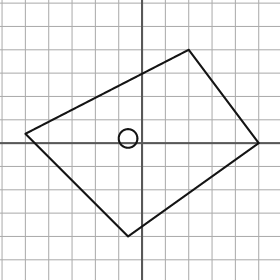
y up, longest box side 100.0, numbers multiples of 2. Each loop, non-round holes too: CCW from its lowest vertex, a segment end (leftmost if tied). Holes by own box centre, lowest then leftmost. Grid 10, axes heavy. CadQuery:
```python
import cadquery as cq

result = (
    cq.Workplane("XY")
    .moveTo(-6.0, -40.0)
    .lineTo(50.0, 0.0)
    .lineTo(20.0, 40.0)
    .lineTo(-50.0, 4.0)
    .close()
    .moveTo(-6.0, 2.0)
    .circle(4.0)
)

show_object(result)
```